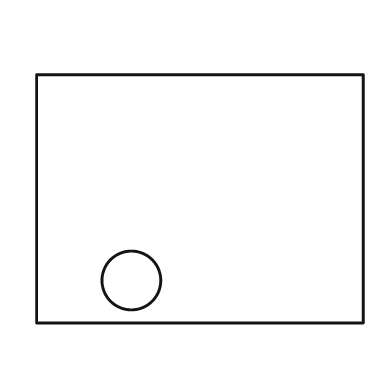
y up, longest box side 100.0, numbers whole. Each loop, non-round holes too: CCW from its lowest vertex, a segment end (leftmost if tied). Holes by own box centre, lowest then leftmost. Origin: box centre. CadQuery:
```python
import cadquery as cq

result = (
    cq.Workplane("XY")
    .moveTo(-50.0, -38.0)
    .lineTo(50.0, -38.0)
    .lineTo(50.0, 38.0)
    .lineTo(-50.0, 38.0)
    .close()
    .moveTo(-21.0, -25.0)
    .circle(9.0)
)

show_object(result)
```